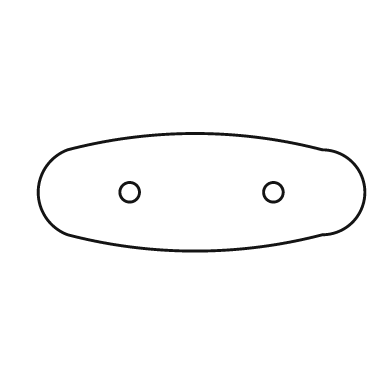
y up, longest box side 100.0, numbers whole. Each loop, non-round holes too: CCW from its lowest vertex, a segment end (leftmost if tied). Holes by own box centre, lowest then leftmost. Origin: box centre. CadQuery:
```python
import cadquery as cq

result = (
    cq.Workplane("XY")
    .moveTo(-41.0, -13.0)
    .threePointArc((-2.0, -18.0), (37.0, -13.0))
    .threePointArc((50.0, 0.0), (37.0, 13.0))
    .threePointArc((-2.0, 18.0), (-41.0, 13.0))
    .threePointArc((-50.0, 0.0), (-41.0, -13.0))
    .close()
    .moveTo(-22.0, 0.0)
    .circle(3.0)
    .moveTo(22.0, 0.0)
    .circle(3.0)
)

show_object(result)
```